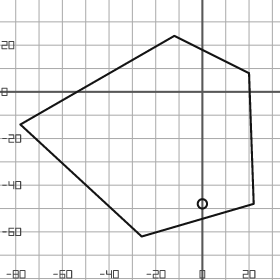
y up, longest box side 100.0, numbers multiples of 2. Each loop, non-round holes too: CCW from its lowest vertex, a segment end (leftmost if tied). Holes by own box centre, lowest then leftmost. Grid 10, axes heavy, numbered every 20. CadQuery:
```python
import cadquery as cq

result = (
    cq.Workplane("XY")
    .moveTo(-26.0, -62.0)
    .lineTo(22.0, -48.0)
    .lineTo(20.0, 8.0)
    .lineTo(-12.0, 24.0)
    .lineTo(-78.0, -14.0)
    .close()
    .moveTo(0.0, -48.0)
    .circle(2.0)
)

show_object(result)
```